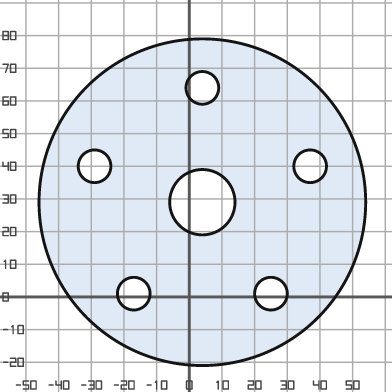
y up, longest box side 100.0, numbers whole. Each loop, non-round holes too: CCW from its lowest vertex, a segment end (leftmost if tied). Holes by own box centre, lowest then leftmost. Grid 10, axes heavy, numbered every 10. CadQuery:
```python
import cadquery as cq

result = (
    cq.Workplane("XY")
    .moveTo(4.0, 29.0)
    .circle(50.0)
    .moveTo(-17.0, 1.0)
    .circle(5.0)
    .moveTo(25.0, 1.0)
    .circle(5.0)
    .moveTo(4.0, 29.0)
    .circle(10.0)
    .moveTo(-29.0, 40.0)
    .circle(5.0)
    .moveTo(37.0, 40.0)
    .circle(5.0)
    .moveTo(4.0, 64.0)
    .circle(5.0)
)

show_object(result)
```